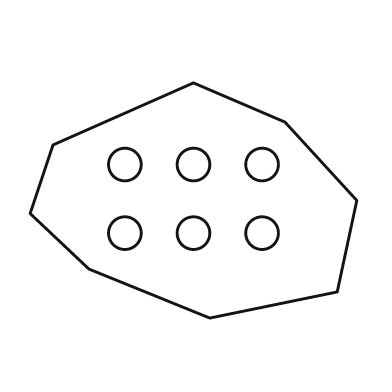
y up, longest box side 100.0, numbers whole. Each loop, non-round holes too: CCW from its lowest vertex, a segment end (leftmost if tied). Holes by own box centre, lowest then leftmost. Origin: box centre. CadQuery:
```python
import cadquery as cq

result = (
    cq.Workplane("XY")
    .moveTo(5.0, -36.0)
    .lineTo(44.0, -28.0)
    .lineTo(50.0, 0.0)
    .lineTo(28.0, 24.0)
    .lineTo(0.0, 36.0)
    .lineTo(-43.0, 17.0)
    .lineTo(-50.0, -4.0)
    .lineTo(-32.0, -21.0)
    .close()
    .moveTo(-21.0, -10.0)
    .circle(5.0)
    .moveTo(0.0, -10.0)
    .circle(5.0)
    .moveTo(21.0, -10.0)
    .circle(5.0)
    .moveTo(-21.0, 11.0)
    .circle(5.0)
    .moveTo(0.0, 11.0)
    .circle(5.0)
    .moveTo(21.0, 11.0)
    .circle(5.0)
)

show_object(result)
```